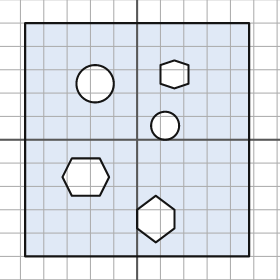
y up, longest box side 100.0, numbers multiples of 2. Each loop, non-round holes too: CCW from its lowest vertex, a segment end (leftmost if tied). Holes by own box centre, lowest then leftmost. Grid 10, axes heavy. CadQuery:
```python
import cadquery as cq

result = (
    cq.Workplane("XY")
    .moveTo(-48.0, -50.0)
    .lineTo(48.0, -50.0)
    .lineTo(48.0, 50.0)
    .lineTo(-48.0, 50.0)
    .close()
    .moveTo(8.0, -44.0)
    .lineTo(16.0, -38.0)
    .lineTo(16.0, -30.0)
    .lineTo(8.0, -24.0)
    .lineTo(0.0, -30.0)
    .lineTo(0.0, -38.0)
    .close()
    .moveTo(-28.0, -24.0)
    .lineTo(-16.0, -24.0)
    .lineTo(-12.0, -16.0)
    .lineTo(-16.0, -8.0)
    .lineTo(-28.0, -8.0)
    .lineTo(-32.0, -16.0)
    .close()
    .moveTo(12.0, 6.0)
    .circle(6.0)
    .moveTo(-18.0, 24.0)
    .circle(8.0)
    .moveTo(16.0, 22.0)
    .lineTo(22.0, 24.0)
    .lineTo(22.0, 32.0)
    .lineTo(16.0, 34.0)
    .lineTo(10.0, 32.0)
    .lineTo(10.0, 24.0)
    .close()
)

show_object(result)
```